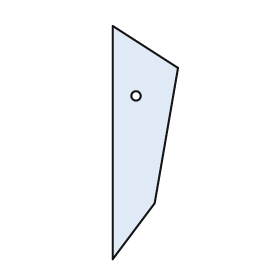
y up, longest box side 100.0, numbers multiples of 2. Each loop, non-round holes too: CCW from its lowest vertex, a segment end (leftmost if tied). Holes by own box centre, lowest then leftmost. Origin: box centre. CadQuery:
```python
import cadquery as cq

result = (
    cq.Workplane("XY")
    .moveTo(-14.0, -50.0)
    .lineTo(4.0, -26.0)
    .lineTo(14.0, 32.0)
    .lineTo(-14.0, 50.0)
    .close()
    .moveTo(-4.0, 20.0)
    .circle(2.0)
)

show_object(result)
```